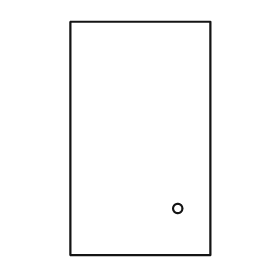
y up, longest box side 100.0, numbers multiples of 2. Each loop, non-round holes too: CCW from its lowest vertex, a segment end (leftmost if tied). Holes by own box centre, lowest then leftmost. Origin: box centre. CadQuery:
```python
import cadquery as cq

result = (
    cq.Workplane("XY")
    .moveTo(-30.0, -50.0)
    .lineTo(30.0, -50.0)
    .lineTo(30.0, 50.0)
    .lineTo(-30.0, 50.0)
    .close()
    .moveTo(16.0, -30.0)
    .circle(2.0)
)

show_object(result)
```